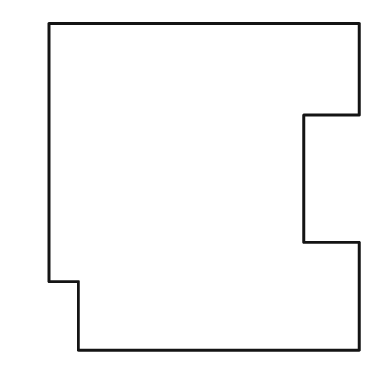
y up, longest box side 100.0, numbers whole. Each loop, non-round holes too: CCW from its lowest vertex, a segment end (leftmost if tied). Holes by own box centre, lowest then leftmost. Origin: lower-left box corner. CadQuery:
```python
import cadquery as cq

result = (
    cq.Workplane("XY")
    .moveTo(9.0, 0.0)
    .lineTo(95.0, 0.0)
    .lineTo(95.0, 33.0)
    .lineTo(78.0, 33.0)
    .lineTo(78.0, 72.0)
    .lineTo(95.0, 72.0)
    .lineTo(95.0, 100.0)
    .lineTo(0.0, 100.0)
    .lineTo(0.0, 21.0)
    .lineTo(9.0, 21.0)
    .close()
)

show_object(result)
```